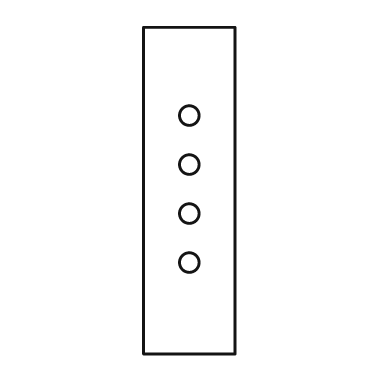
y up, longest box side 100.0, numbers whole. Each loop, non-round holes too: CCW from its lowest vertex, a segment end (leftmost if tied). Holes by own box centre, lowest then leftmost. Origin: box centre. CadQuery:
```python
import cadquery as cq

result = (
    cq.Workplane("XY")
    .moveTo(-14.0, -50.0)
    .lineTo(14.0, -50.0)
    .lineTo(14.0, 50.0)
    .lineTo(-14.0, 50.0)
    .close()
    .moveTo(0.0, -22.0)
    .circle(3.0)
    .moveTo(0.0, -7.0)
    .circle(3.0)
    .moveTo(0.0, 8.0)
    .circle(3.0)
    .moveTo(0.0, 23.0)
    .circle(3.0)
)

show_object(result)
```